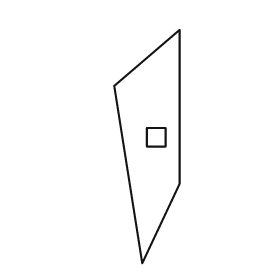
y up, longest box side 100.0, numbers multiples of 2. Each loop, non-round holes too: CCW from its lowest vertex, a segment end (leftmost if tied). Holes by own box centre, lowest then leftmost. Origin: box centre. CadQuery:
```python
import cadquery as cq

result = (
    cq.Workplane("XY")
    .moveTo(-2.0, -50.0)
    .lineTo(14.0, -16.0)
    .lineTo(14.0, 50.0)
    .lineTo(-14.0, 26.0)
    .close()
    .moveTo(0.0, 0.0)
    .lineTo(8.0, 0.0)
    .lineTo(8.0, 8.0)
    .lineTo(0.0, 8.0)
    .close()
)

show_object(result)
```